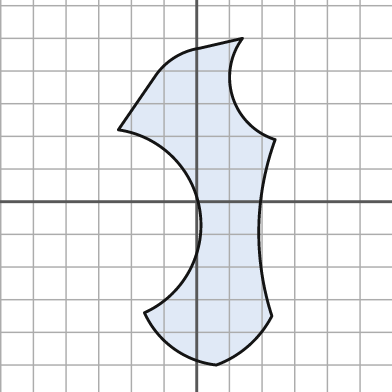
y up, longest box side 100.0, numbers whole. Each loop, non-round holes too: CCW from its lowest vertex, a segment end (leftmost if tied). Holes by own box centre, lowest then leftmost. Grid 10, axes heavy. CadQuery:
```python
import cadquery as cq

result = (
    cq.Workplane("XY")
    .moveTo(6.0, -50.0)
    .threePointArc((16.0, -44.0), (23.0, -35.0))
    .threePointArc((19.0, -8.0), (24.0, 19.0))
    .threePointArc((11.0, 32.0), (14.0, 50.0))
    .lineTo(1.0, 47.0)
    .threePointArc((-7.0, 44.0), (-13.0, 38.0))
    .lineTo(-24.0, 22.0)
    .threePointArc((1.0, -3.0), (-16.0, -34.0))
    .threePointArc((-7.0, -45.0), (6.0, -50.0))
    .close()
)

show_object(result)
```